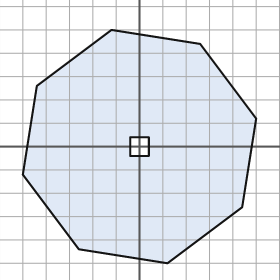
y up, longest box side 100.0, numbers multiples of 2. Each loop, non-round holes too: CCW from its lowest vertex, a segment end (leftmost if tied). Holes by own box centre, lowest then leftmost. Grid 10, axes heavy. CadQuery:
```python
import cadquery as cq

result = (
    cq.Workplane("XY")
    .moveTo(12.0, -50.0)
    .lineTo(44.0, -26.0)
    .lineTo(50.0, 12.0)
    .lineTo(26.0, 44.0)
    .lineTo(-12.0, 50.0)
    .lineTo(-44.0, 26.0)
    .lineTo(-50.0, -12.0)
    .lineTo(-26.0, -44.0)
    .close()
    .moveTo(-4.0, -4.0)
    .lineTo(4.0, -4.0)
    .lineTo(4.0, 4.0)
    .lineTo(-4.0, 4.0)
    .close()
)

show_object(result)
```